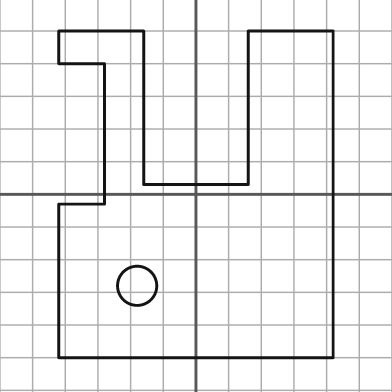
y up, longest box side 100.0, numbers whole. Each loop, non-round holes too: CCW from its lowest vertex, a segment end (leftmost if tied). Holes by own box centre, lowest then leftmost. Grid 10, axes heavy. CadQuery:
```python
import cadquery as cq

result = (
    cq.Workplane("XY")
    .moveTo(-42.0, -50.0)
    .lineTo(42.0, -50.0)
    .lineTo(42.0, 50.0)
    .lineTo(16.0, 50.0)
    .lineTo(16.0, 3.0)
    .lineTo(-16.0, 3.0)
    .lineTo(-16.0, 50.0)
    .lineTo(-42.0, 50.0)
    .lineTo(-42.0, 40.0)
    .lineTo(-28.0, 40.0)
    .lineTo(-28.0, -3.0)
    .lineTo(-42.0, -3.0)
    .close()
    .moveTo(-18.0, -28.0)
    .circle(6.0)
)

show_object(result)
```